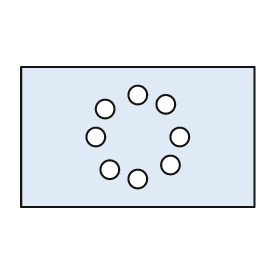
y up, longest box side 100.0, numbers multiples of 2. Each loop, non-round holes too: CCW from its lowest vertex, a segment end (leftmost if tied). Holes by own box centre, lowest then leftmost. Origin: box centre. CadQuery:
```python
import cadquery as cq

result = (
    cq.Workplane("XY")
    .moveTo(-50.0, -30.0)
    .lineTo(50.0, -30.0)
    .lineTo(50.0, 30.0)
    .lineTo(-50.0, 30.0)
    .close()
    .moveTo(0.0, -18.0)
    .circle(4.0)
    .moveTo(-12.0, -14.0)
    .circle(4.0)
    .moveTo(14.0, -12.0)
    .circle(4.0)
    .moveTo(-18.0, 0.0)
    .circle(4.0)
    .moveTo(18.0, 0.0)
    .circle(4.0)
    .moveTo(-14.0, 12.0)
    .circle(4.0)
    .moveTo(12.0, 14.0)
    .circle(4.0)
    .moveTo(0.0, 18.0)
    .circle(4.0)
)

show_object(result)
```